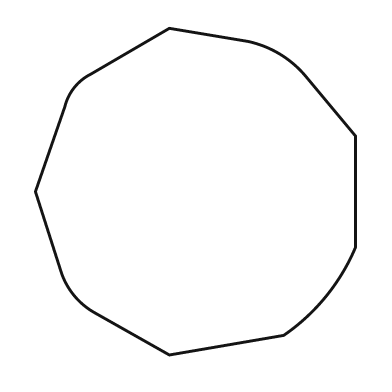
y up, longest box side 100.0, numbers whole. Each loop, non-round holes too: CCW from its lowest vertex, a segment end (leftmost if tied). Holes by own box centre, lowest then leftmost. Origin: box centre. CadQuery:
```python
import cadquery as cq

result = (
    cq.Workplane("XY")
    .moveTo(-8.0, -50.0)
    .lineTo(27.0, -44.0)
    .threePointArc((40.0, -32.0), (49.0, -17.0))
    .lineTo(49.0, 17.0)
    .lineTo(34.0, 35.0)
    .threePointArc((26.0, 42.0), (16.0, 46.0))
    .lineTo(-8.0, 50.0)
    .lineTo(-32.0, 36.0)
    .threePointArc((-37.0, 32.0), (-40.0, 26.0))
    .lineTo(-49.0, 0.0)
    .lineTo(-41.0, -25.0)
    .threePointArc((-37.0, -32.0), (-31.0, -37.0))
    .close()
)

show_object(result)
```